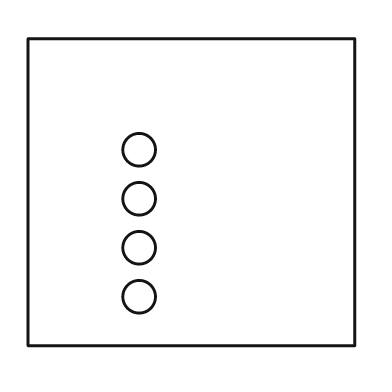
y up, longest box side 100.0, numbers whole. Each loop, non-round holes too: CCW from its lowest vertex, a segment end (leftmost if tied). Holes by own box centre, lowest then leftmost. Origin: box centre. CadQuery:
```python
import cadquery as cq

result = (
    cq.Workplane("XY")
    .moveTo(-50.0, -47.0)
    .lineTo(50.0, -47.0)
    .lineTo(50.0, 47.0)
    .lineTo(-50.0, 47.0)
    .close()
    .moveTo(-16.0, -32.0)
    .circle(5.0)
    .moveTo(-16.0, -17.0)
    .circle(5.0)
    .moveTo(-16.0, -2.0)
    .circle(5.0)
    .moveTo(-16.0, 13.0)
    .circle(5.0)
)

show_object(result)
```